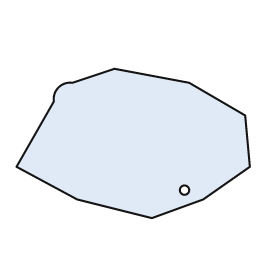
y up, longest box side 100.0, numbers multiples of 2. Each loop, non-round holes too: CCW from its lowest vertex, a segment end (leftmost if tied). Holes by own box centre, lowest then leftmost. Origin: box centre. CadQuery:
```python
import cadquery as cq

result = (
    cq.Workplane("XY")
    .moveTo(8.0, -32.0)
    .lineTo(30.0, -24.0)
    .lineTo(50.0, -10.0)
    .lineTo(48.0, 12.0)
    .lineTo(24.0, 26.0)
    .lineTo(-8.0, 32.0)
    .lineTo(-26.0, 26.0)
    .threePointArc((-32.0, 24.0), (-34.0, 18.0))
    .lineTo(-50.0, -10.0)
    .lineTo(-24.0, -24.0)
    .close()
    .moveTo(22.0, -20.0)
    .circle(2.0)
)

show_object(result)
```